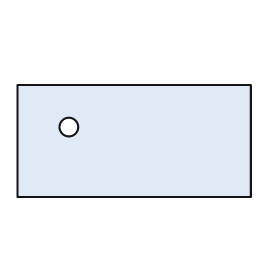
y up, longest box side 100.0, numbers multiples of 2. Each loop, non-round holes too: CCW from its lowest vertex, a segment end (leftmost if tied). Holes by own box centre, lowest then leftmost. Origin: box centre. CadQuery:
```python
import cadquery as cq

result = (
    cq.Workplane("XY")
    .moveTo(-50.0, -24.0)
    .lineTo(50.0, -24.0)
    .lineTo(50.0, 24.0)
    .lineTo(-50.0, 24.0)
    .close()
    .moveTo(-28.0, 6.0)
    .circle(4.0)
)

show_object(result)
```